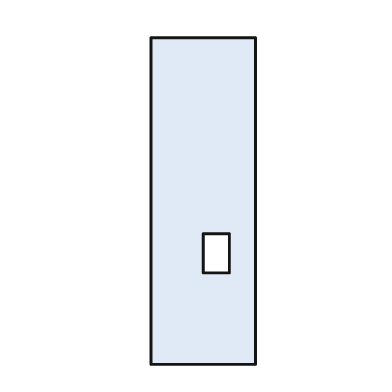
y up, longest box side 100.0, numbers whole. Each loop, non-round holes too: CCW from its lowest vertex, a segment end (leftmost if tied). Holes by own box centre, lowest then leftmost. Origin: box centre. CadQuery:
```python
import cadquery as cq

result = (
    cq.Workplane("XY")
    .moveTo(-16.0, -50.0)
    .lineTo(16.0, -50.0)
    .lineTo(16.0, 50.0)
    .lineTo(-16.0, 50.0)
    .close()
    .moveTo(0.0, -22.0)
    .lineTo(8.0, -22.0)
    .lineTo(8.0, -10.0)
    .lineTo(0.0, -10.0)
    .close()
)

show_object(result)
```